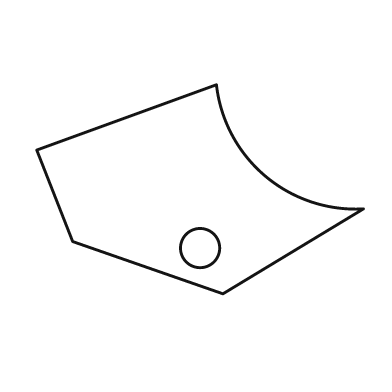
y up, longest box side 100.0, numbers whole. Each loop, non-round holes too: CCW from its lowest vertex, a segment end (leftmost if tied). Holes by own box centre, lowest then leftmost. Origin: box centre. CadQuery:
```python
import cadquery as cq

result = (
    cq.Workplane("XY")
    .moveTo(7.0, -32.0)
    .lineTo(50.0, -6.0)
    .threePointArc((20.0, 4.0), (5.0, 32.0))
    .lineTo(-50.0, 12.0)
    .lineTo(-39.0, -16.0)
    .close()
    .moveTo(0.0, -18.0)
    .circle(6.0)
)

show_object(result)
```